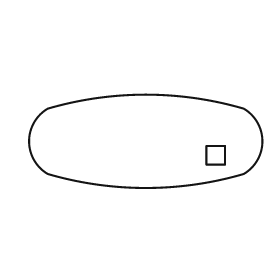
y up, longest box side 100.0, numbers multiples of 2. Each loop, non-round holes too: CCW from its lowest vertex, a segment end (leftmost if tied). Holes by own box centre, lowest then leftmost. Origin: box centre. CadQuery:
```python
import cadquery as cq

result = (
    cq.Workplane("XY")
    .moveTo(-42.0, -14.0)
    .threePointArc((0.0, -20.0), (42.0, -14.0))
    .threePointArc((50.0, 0.0), (42.0, 14.0))
    .threePointArc((0.0, 20.0), (-42.0, 14.0))
    .threePointArc((-50.0, 0.0), (-42.0, -14.0))
    .close()
    .moveTo(26.0, -10.0)
    .lineTo(34.0, -10.0)
    .lineTo(34.0, -2.0)
    .lineTo(26.0, -2.0)
    .close()
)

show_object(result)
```